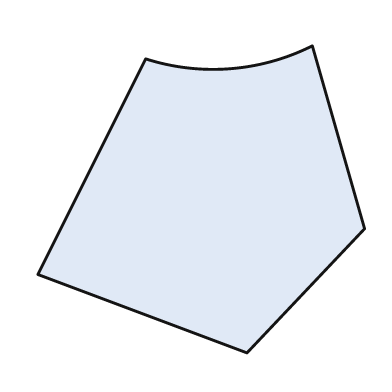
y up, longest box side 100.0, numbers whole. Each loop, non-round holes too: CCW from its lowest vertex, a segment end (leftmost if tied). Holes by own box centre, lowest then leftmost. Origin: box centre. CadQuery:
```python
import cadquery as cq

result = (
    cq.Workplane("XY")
    .moveTo(14.0, -47.0)
    .lineTo(50.0, -9.0)
    .lineTo(34.0, 47.0)
    .threePointArc((9.0, 40.0), (-17.0, 43.0))
    .lineTo(-50.0, -23.0)
    .close()
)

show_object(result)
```